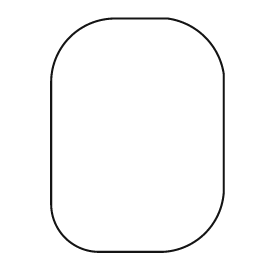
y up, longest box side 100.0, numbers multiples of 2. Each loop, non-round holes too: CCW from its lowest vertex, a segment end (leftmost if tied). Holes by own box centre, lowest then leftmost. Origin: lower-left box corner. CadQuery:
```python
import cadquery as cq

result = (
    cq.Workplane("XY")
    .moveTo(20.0, 0.0)
    .lineTo(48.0, 0.0)
    .threePointArc((66.0, 8.0), (74.0, 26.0))
    .lineTo(74.0, 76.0)
    .threePointArc((66.0, 92.0), (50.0, 100.0))
    .lineTo(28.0, 100.0)
    .threePointArc((8.0, 92.0), (0.0, 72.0))
    .lineTo(0.0, 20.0)
    .threePointArc((6.0, 6.0), (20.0, 0.0))
    .close()
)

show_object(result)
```